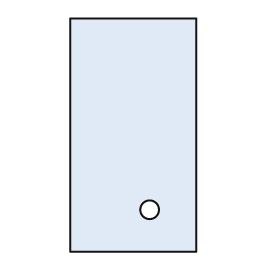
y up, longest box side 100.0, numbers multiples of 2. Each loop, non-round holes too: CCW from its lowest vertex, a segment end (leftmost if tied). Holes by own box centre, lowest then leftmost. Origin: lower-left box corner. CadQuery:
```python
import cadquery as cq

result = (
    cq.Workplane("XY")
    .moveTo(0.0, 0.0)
    .lineTo(54.0, 0.0)
    .lineTo(54.0, 100.0)
    .lineTo(0.0, 100.0)
    .close()
    .moveTo(34.0, 18.0)
    .circle(4.0)
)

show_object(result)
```